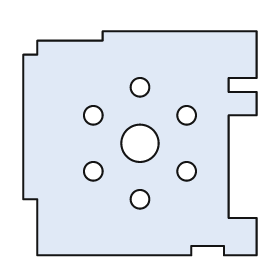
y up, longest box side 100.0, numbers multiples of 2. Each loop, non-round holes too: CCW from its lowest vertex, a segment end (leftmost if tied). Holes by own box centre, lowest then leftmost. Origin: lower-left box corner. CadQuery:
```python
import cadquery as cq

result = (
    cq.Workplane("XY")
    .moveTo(6.0, 0.0)
    .lineTo(72.0, 0.0)
    .lineTo(72.0, 4.0)
    .lineTo(86.0, 4.0)
    .lineTo(86.0, 0.0)
    .lineTo(100.0, 0.0)
    .lineTo(100.0, 16.0)
    .lineTo(88.0, 16.0)
    .lineTo(88.0, 60.0)
    .lineTo(100.0, 60.0)
    .lineTo(100.0, 70.0)
    .lineTo(88.0, 70.0)
    .lineTo(88.0, 76.0)
    .lineTo(100.0, 76.0)
    .lineTo(100.0, 96.0)
    .lineTo(34.0, 96.0)
    .lineTo(34.0, 92.0)
    .lineTo(6.0, 92.0)
    .lineTo(6.0, 86.0)
    .lineTo(0.0, 86.0)
    .lineTo(0.0, 24.0)
    .lineTo(6.0, 24.0)
    .close()
    .moveTo(50.0, 24.0)
    .circle(4.0)
    .moveTo(30.0, 36.0)
    .circle(4.0)
    .moveTo(70.0, 36.0)
    .circle(4.0)
    .moveTo(50.0, 48.0)
    .circle(8.0)
    .moveTo(30.0, 60.0)
    .circle(4.0)
    .moveTo(70.0, 60.0)
    .circle(4.0)
    .moveTo(50.0, 72.0)
    .circle(4.0)
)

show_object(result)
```